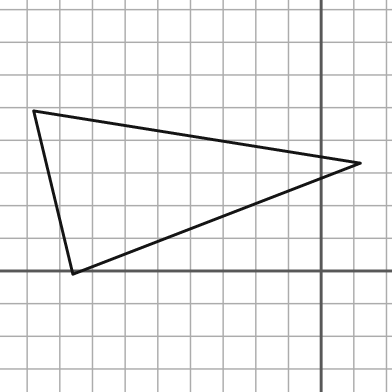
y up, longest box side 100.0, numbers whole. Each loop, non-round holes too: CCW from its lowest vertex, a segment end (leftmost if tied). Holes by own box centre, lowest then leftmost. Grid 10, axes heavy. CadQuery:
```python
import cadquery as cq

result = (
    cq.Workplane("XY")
    .moveTo(-76.0, -1.0)
    .lineTo(12.0, 33.0)
    .lineTo(-88.0, 49.0)
    .close()
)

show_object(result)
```